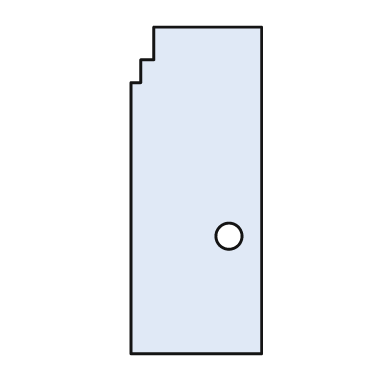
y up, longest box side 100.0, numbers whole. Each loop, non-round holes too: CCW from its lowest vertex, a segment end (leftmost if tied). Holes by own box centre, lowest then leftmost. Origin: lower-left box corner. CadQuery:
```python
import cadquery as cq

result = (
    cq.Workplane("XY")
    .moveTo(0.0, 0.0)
    .lineTo(40.0, 0.0)
    .lineTo(40.0, 100.0)
    .lineTo(7.0, 100.0)
    .lineTo(7.0, 90.0)
    .lineTo(3.0, 90.0)
    .lineTo(3.0, 83.0)
    .lineTo(0.0, 83.0)
    .close()
    .moveTo(30.0, 36.0)
    .circle(4.0)
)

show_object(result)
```